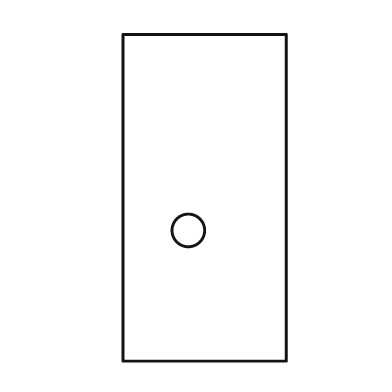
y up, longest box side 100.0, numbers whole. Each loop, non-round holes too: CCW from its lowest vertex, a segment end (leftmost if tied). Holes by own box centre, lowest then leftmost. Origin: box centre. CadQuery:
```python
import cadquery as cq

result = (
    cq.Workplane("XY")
    .moveTo(-25.0, -50.0)
    .lineTo(25.0, -50.0)
    .lineTo(25.0, 50.0)
    .lineTo(-25.0, 50.0)
    .close()
    .moveTo(-5.0, -10.0)
    .circle(5.0)
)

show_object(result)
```